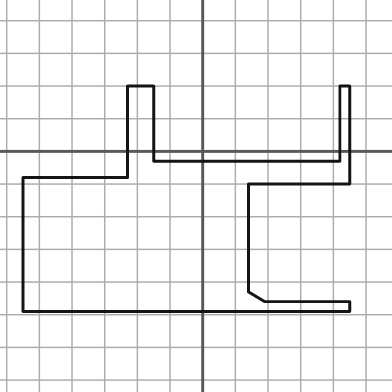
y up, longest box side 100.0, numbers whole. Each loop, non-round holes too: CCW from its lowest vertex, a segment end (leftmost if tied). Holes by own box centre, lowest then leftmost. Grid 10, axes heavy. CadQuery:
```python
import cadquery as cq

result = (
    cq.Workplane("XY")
    .moveTo(-55.0, -49.0)
    .lineTo(45.0, -49.0)
    .lineTo(45.0, -46.0)
    .lineTo(19.0, -46.0)
    .lineTo(14.0, -43.0)
    .lineTo(14.0, -10.0)
    .lineTo(45.0, -10.0)
    .lineTo(45.0, 20.0)
    .lineTo(42.0, 20.0)
    .lineTo(42.0, -3.0)
    .lineTo(-15.0, -3.0)
    .lineTo(-15.0, 20.0)
    .lineTo(-23.0, 20.0)
    .lineTo(-23.0, -8.0)
    .lineTo(-55.0, -8.0)
    .close()
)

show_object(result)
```